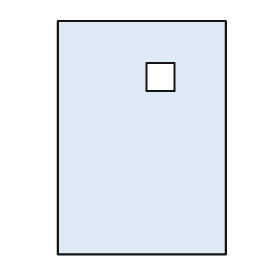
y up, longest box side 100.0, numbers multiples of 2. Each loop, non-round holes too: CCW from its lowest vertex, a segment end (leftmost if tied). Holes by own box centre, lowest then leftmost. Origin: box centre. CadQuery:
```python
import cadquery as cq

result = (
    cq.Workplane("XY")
    .moveTo(-36.0, -50.0)
    .lineTo(36.0, -50.0)
    .lineTo(36.0, 50.0)
    .lineTo(-36.0, 50.0)
    .close()
    .moveTo(2.0, 20.0)
    .lineTo(14.0, 20.0)
    .lineTo(14.0, 32.0)
    .lineTo(2.0, 32.0)
    .close()
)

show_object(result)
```